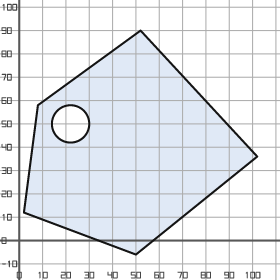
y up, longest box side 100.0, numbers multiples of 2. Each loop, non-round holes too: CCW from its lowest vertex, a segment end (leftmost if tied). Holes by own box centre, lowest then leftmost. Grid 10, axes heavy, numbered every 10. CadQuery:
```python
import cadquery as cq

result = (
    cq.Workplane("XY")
    .moveTo(50.0, -6.0)
    .lineTo(102.0, 36.0)
    .lineTo(52.0, 90.0)
    .lineTo(8.0, 58.0)
    .lineTo(2.0, 12.0)
    .close()
    .moveTo(22.0, 50.0)
    .circle(8.0)
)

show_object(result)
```